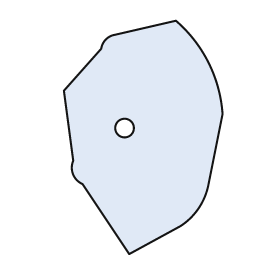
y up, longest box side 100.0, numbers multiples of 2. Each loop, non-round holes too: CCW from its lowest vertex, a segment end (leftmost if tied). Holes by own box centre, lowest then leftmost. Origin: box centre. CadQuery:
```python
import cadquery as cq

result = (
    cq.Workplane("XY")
    .moveTo(-6.0, -50.0)
    .lineTo(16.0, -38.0)
    .threePointArc((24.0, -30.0), (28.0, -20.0))
    .lineTo(34.0, 10.0)
    .threePointArc((28.0, 32.0), (14.0, 50.0))
    .lineTo(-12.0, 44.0)
    .threePointArc((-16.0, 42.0), (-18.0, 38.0))
    .lineTo(-34.0, 20.0)
    .lineTo(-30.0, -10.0)
    .threePointArc((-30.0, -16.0), (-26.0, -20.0))
    .close()
    .moveTo(-8.0, 4.0)
    .circle(4.0)
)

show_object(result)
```